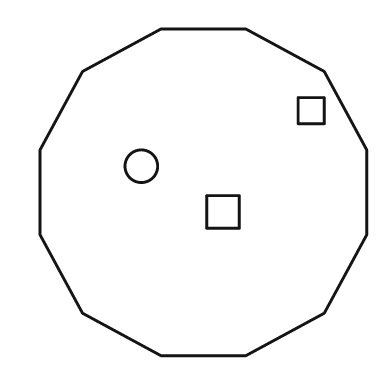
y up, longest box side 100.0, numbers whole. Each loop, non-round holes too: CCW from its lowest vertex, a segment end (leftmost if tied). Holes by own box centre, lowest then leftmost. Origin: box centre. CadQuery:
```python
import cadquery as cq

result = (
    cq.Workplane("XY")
    .moveTo(-13.0, -50.0)
    .lineTo(13.0, -50.0)
    .lineTo(37.0, -37.0)
    .lineTo(50.0, -13.0)
    .lineTo(50.0, 13.0)
    .lineTo(37.0, 37.0)
    .lineTo(13.0, 50.0)
    .lineTo(-13.0, 50.0)
    .lineTo(-37.0, 37.0)
    .lineTo(-50.0, 13.0)
    .lineTo(-50.0, -13.0)
    .lineTo(-37.0, -37.0)
    .close()
    .moveTo(1.0, -11.0)
    .lineTo(11.0, -11.0)
    .lineTo(11.0, -1.0)
    .lineTo(1.0, -1.0)
    .close()
    .moveTo(-19.0, 8.0)
    .circle(5.0)
    .moveTo(29.0, 21.0)
    .lineTo(37.0, 21.0)
    .lineTo(37.0, 29.0)
    .lineTo(29.0, 29.0)
    .close()
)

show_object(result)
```